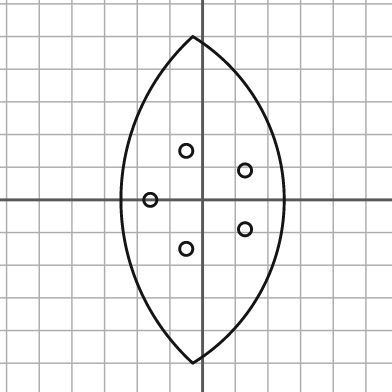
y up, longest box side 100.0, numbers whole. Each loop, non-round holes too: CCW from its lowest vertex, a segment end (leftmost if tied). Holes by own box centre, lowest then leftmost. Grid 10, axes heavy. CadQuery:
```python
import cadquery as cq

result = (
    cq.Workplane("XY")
    .moveTo(-3.0, -50.0)
    .threePointArc((25.0, 0.0), (-3.0, 50.0))
    .threePointArc((-25.0, 0.0), (-3.0, -50.0))
    .close()
    .moveTo(-5.0, -15.0)
    .circle(2.0)
    .moveTo(13.0, -9.0)
    .circle(2.0)
    .moveTo(-16.0, 0.0)
    .circle(2.0)
    .moveTo(13.0, 9.0)
    .circle(2.0)
    .moveTo(-5.0, 15.0)
    .circle(2.0)
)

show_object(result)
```